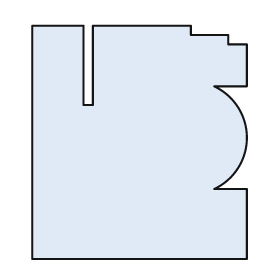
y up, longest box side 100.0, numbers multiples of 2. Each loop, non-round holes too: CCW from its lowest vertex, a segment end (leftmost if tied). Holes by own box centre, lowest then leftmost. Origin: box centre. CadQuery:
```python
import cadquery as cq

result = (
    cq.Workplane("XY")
    .moveTo(-46.0, -50.0)
    .lineTo(46.0, -50.0)
    .lineTo(46.0, -20.0)
    .lineTo(32.0, -20.0)
    .threePointArc((46.0, 2.0), (32.0, 24.0))
    .lineTo(46.0, 24.0)
    .lineTo(46.0, 42.0)
    .lineTo(38.0, 42.0)
    .lineTo(38.0, 46.0)
    .lineTo(22.0, 46.0)
    .lineTo(22.0, 50.0)
    .lineTo(-20.0, 50.0)
    .lineTo(-20.0, 16.0)
    .lineTo(-24.0, 16.0)
    .lineTo(-24.0, 50.0)
    .lineTo(-46.0, 50.0)
    .close()
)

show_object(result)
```